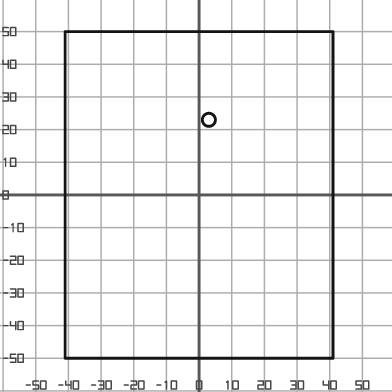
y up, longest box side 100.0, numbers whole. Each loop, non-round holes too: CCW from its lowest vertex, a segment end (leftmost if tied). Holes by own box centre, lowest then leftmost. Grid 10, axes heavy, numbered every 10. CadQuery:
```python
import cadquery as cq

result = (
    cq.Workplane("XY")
    .moveTo(-41.0, -50.0)
    .lineTo(41.0, -50.0)
    .lineTo(41.0, 50.0)
    .lineTo(-41.0, 50.0)
    .close()
    .moveTo(3.0, 23.0)
    .circle(2.0)
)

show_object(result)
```